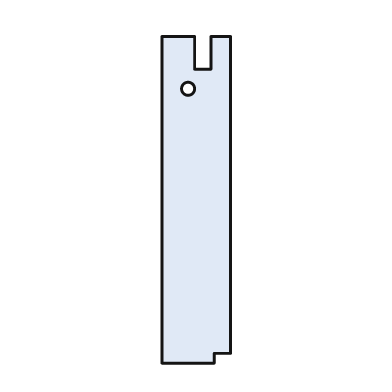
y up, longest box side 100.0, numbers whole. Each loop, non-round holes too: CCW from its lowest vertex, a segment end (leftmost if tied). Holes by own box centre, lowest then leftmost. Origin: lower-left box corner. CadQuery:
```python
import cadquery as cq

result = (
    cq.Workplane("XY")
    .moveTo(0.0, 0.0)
    .lineTo(16.0, 0.0)
    .lineTo(16.0, 3.0)
    .lineTo(21.0, 3.0)
    .lineTo(21.0, 100.0)
    .lineTo(15.0, 100.0)
    .lineTo(15.0, 90.0)
    .lineTo(10.0, 90.0)
    .lineTo(10.0, 100.0)
    .lineTo(0.0, 100.0)
    .close()
    .moveTo(8.0, 84.0)
    .circle(2.0)
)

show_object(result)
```